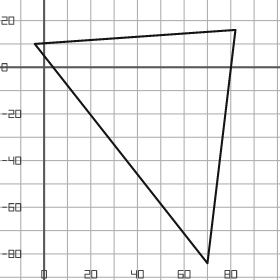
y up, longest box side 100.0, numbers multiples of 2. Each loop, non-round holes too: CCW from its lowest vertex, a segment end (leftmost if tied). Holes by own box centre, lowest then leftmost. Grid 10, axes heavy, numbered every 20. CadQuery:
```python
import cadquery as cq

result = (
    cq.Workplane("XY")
    .moveTo(70.0, -84.0)
    .lineTo(82.0, 16.0)
    .lineTo(-4.0, 10.0)
    .close()
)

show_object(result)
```